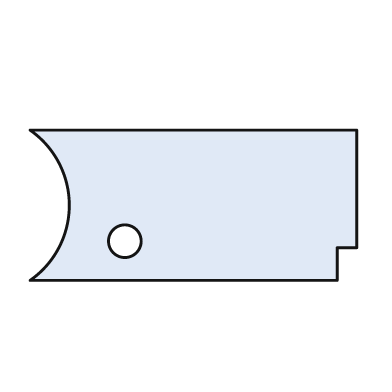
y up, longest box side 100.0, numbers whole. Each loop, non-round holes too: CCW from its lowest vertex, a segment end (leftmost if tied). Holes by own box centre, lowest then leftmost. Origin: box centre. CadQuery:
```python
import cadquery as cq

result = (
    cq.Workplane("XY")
    .moveTo(-50.0, -23.0)
    .lineTo(44.0, -23.0)
    .lineTo(44.0, -13.0)
    .lineTo(50.0, -13.0)
    .lineTo(50.0, 23.0)
    .lineTo(-50.0, 23.0)
    .threePointArc((-38.0, 0.0), (-50.0, -23.0))
    .close()
    .moveTo(-21.0, -11.0)
    .circle(5.0)
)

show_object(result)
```